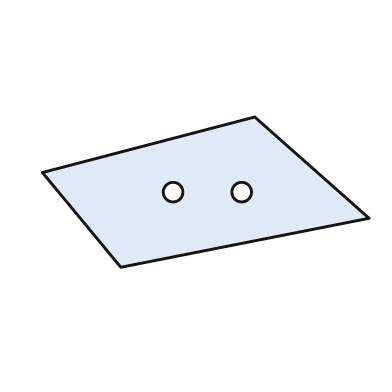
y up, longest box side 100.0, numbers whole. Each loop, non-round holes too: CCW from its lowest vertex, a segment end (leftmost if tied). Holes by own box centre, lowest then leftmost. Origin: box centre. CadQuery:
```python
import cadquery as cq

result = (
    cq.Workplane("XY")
    .moveTo(-26.0, -23.0)
    .lineTo(50.0, -8.0)
    .lineTo(15.0, 23.0)
    .lineTo(-50.0, 6.0)
    .close()
    .moveTo(-10.0, 0.0)
    .circle(3.0)
    .moveTo(11.0, 0.0)
    .circle(3.0)
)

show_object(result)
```